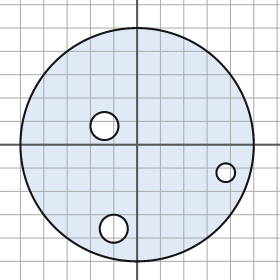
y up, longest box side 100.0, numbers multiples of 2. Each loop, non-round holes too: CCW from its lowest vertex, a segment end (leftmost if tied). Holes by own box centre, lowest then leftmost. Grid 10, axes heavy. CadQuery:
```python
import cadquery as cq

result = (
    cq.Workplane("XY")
    .moveTo(0.0, 0.0)
    .circle(50.0)
    .moveTo(-10.0, -36.0)
    .circle(6.0)
    .moveTo(38.0, -12.0)
    .circle(4.0)
    .moveTo(-14.0, 8.0)
    .circle(6.0)
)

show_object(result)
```